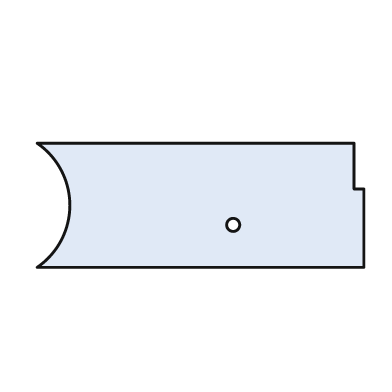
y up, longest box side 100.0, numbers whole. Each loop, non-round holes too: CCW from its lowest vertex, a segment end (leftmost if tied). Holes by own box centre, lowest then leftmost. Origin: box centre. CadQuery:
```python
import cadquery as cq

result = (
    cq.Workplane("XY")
    .moveTo(-50.0, -19.0)
    .lineTo(50.0, -19.0)
    .lineTo(50.0, 5.0)
    .lineTo(47.0, 5.0)
    .lineTo(47.0, 19.0)
    .lineTo(-50.0, 19.0)
    .threePointArc((-40.0, 0.0), (-50.0, -19.0))
    .close()
    .moveTo(10.0, -6.0)
    .circle(2.0)
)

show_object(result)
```